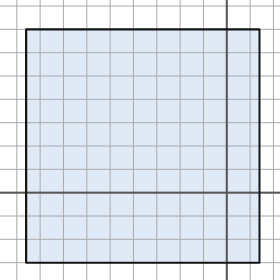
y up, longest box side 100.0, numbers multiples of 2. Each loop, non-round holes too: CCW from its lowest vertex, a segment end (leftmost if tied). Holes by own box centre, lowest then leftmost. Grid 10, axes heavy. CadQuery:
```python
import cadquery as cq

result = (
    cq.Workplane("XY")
    .moveTo(-86.0, -30.0)
    .lineTo(14.0, -30.0)
    .lineTo(14.0, 70.0)
    .lineTo(-86.0, 70.0)
    .close()
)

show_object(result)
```